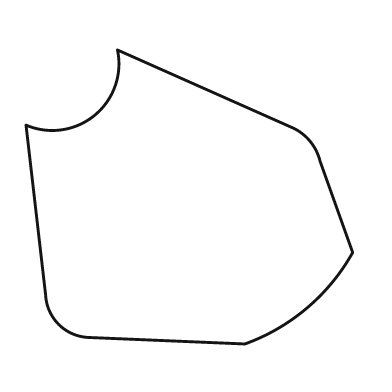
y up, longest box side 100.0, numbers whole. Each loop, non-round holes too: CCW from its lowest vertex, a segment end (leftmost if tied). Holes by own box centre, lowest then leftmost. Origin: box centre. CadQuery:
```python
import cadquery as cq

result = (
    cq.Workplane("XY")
    .moveTo(17.0, -45.0)
    .threePointArc((36.0, -34.0), (50.0, -17.0))
    .lineTo(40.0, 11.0)
    .threePointArc((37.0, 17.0), (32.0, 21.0))
    .lineTo(-22.0, 45.0)
    .threePointArc((-29.0, 25.0), (-50.0, 22.0))
    .lineTo(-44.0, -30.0)
    .threePointArc((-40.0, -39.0), (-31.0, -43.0))
    .close()
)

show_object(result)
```